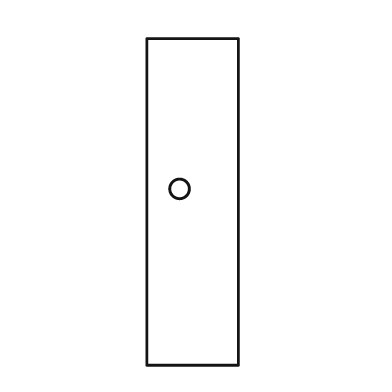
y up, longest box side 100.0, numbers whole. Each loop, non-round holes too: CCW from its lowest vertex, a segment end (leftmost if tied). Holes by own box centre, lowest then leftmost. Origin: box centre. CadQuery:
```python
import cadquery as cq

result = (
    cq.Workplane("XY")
    .moveTo(-14.0, -50.0)
    .lineTo(14.0, -50.0)
    .lineTo(14.0, 50.0)
    .lineTo(-14.0, 50.0)
    .close()
    .moveTo(-4.0, 4.0)
    .circle(3.0)
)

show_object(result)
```